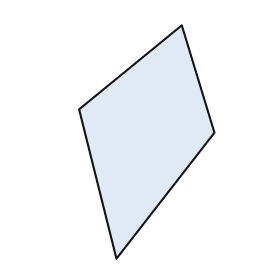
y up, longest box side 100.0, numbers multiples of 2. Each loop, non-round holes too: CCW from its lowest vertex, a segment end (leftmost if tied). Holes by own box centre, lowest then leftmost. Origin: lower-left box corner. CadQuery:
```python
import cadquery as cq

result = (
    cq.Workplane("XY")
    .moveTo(16.0, 0.0)
    .lineTo(58.0, 54.0)
    .lineTo(44.0, 100.0)
    .lineTo(0.0, 64.0)
    .close()
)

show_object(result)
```